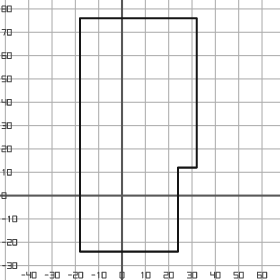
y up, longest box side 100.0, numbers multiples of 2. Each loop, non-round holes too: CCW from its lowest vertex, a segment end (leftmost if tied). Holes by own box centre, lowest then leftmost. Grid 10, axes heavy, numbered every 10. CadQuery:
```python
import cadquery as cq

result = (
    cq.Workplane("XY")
    .moveTo(-18.0, -24.0)
    .lineTo(24.0, -24.0)
    .lineTo(24.0, 12.0)
    .lineTo(32.0, 12.0)
    .lineTo(32.0, 76.0)
    .lineTo(-18.0, 76.0)
    .close()
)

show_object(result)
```